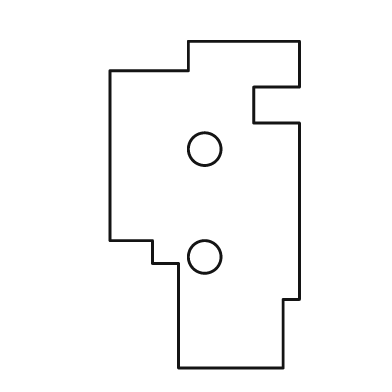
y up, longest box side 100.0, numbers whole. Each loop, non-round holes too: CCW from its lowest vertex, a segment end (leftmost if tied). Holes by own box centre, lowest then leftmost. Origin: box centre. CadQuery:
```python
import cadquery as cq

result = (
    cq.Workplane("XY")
    .moveTo(-8.0, -50.0)
    .lineTo(24.0, -50.0)
    .lineTo(24.0, -29.0)
    .lineTo(29.0, -29.0)
    .lineTo(29.0, 25.0)
    .lineTo(15.0, 25.0)
    .lineTo(15.0, 36.0)
    .lineTo(29.0, 36.0)
    .lineTo(29.0, 50.0)
    .lineTo(-5.0, 50.0)
    .lineTo(-5.0, 41.0)
    .lineTo(-29.0, 41.0)
    .lineTo(-29.0, -11.0)
    .lineTo(-16.0, -11.0)
    .lineTo(-16.0, -18.0)
    .lineTo(-8.0, -18.0)
    .close()
    .moveTo(0.0, -16.0)
    .circle(5.0)
    .moveTo(0.0, 17.0)
    .circle(5.0)
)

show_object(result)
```